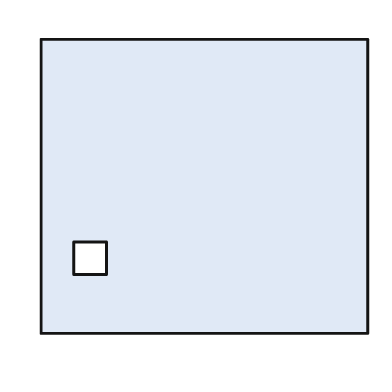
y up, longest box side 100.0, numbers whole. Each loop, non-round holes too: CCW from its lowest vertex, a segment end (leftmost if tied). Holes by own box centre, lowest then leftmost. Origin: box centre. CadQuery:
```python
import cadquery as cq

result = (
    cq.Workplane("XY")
    .moveTo(-50.0, -45.0)
    .lineTo(50.0, -45.0)
    .lineTo(50.0, 45.0)
    .lineTo(-50.0, 45.0)
    .close()
    .moveTo(-40.0, -27.0)
    .lineTo(-30.0, -27.0)
    .lineTo(-30.0, -17.0)
    .lineTo(-40.0, -17.0)
    .close()
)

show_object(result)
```